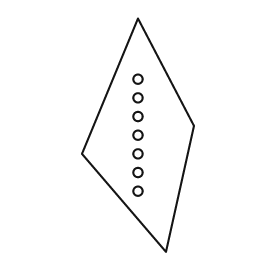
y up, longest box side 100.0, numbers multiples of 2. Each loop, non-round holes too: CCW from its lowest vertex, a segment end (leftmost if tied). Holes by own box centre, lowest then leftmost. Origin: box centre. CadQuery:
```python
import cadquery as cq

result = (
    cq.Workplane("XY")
    .moveTo(12.0, -50.0)
    .lineTo(24.0, 4.0)
    .lineTo(0.0, 50.0)
    .lineTo(-24.0, -8.0)
    .close()
    .moveTo(0.0, -24.0)
    .circle(2.0)
    .moveTo(0.0, -16.0)
    .circle(2.0)
    .moveTo(0.0, -8.0)
    .circle(2.0)
    .moveTo(0.0, 0.0)
    .circle(2.0)
    .moveTo(0.0, 8.0)
    .circle(2.0)
    .moveTo(0.0, 16.0)
    .circle(2.0)
    .moveTo(0.0, 24.0)
    .circle(2.0)
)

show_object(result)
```